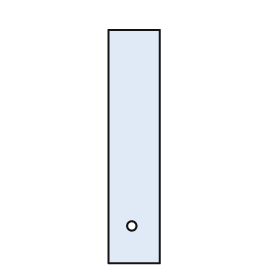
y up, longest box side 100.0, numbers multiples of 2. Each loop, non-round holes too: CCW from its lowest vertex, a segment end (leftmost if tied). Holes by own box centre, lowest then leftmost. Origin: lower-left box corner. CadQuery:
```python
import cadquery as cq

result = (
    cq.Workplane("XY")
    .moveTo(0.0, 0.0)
    .lineTo(22.0, 0.0)
    .lineTo(22.0, 100.0)
    .lineTo(0.0, 100.0)
    .close()
    .moveTo(10.0, 16.0)
    .circle(2.0)
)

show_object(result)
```